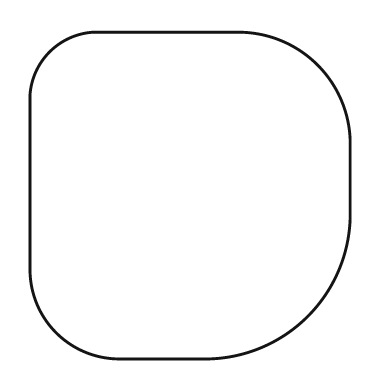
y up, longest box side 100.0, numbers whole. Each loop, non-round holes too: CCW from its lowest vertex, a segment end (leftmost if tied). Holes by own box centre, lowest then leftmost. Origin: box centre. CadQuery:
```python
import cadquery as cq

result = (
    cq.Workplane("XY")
    .moveTo(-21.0, -50.0)
    .lineTo(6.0, -50.0)
    .threePointArc((36.0, -37.0), (49.0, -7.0))
    .lineTo(49.0, 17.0)
    .threePointArc((39.0, 40.0), (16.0, 50.0))
    .lineTo(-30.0, 50.0)
    .threePointArc((-43.0, 44.0), (-49.0, 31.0))
    .lineTo(-49.0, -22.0)
    .threePointArc((-41.0, -42.0), (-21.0, -50.0))
    .close()
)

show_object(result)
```